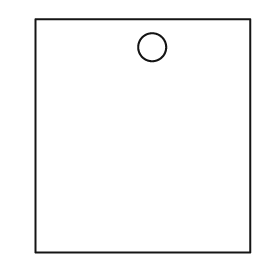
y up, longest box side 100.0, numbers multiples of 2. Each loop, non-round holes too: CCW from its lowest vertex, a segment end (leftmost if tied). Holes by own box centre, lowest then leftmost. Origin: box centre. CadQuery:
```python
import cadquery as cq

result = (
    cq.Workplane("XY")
    .moveTo(-46.0, -50.0)
    .lineTo(46.0, -50.0)
    .lineTo(46.0, 50.0)
    .lineTo(-46.0, 50.0)
    .close()
    .moveTo(4.0, 38.0)
    .circle(6.0)
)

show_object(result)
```